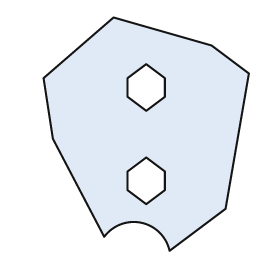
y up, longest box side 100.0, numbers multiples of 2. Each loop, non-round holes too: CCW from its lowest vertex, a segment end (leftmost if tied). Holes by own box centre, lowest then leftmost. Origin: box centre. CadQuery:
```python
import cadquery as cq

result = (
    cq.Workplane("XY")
    .moveTo(10.0, -50.0)
    .lineTo(34.0, -32.0)
    .lineTo(44.0, 26.0)
    .lineTo(28.0, 38.0)
    .lineTo(-14.0, 50.0)
    .lineTo(-44.0, 24.0)
    .lineTo(-40.0, -2.0)
    .lineTo(-18.0, -44.0)
    .threePointArc((-2.0, -38.0), (10.0, -50.0))
    .close()
    .moveTo(0.0, -30.0)
    .lineTo(8.0, -24.0)
    .lineTo(8.0, -16.0)
    .lineTo(0.0, -10.0)
    .lineTo(-8.0, -16.0)
    .lineTo(-8.0, -24.0)
    .close()
    .moveTo(0.0, 10.0)
    .lineTo(8.0, 16.0)
    .lineTo(8.0, 24.0)
    .lineTo(0.0, 30.0)
    .lineTo(-8.0, 24.0)
    .lineTo(-8.0, 16.0)
    .close()
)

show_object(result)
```